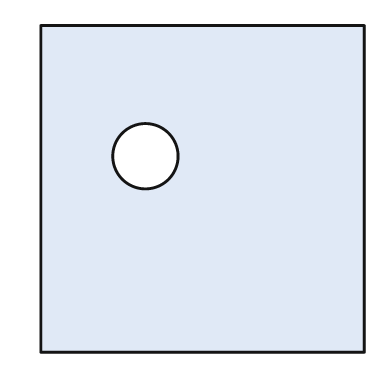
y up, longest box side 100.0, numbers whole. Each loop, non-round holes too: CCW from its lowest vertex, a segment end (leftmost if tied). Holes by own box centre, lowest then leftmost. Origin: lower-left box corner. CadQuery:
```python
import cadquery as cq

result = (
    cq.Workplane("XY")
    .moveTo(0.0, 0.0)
    .lineTo(99.0, 0.0)
    .lineTo(99.0, 100.0)
    .lineTo(0.0, 100.0)
    .close()
    .moveTo(32.0, 60.0)
    .circle(10.0)
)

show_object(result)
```